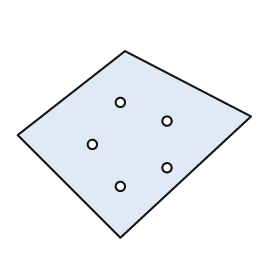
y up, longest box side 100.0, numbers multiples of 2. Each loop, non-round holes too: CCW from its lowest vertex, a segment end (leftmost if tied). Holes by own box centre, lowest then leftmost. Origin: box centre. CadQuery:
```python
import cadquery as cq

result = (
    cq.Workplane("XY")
    .moveTo(-6.0, -40.0)
    .lineTo(50.0, 12.0)
    .lineTo(-4.0, 40.0)
    .lineTo(-50.0, 4.0)
    .close()
    .moveTo(-6.0, -18.0)
    .circle(2.0)
    .moveTo(14.0, -10.0)
    .circle(2.0)
    .moveTo(-18.0, 0.0)
    .circle(2.0)
    .moveTo(14.0, 10.0)
    .circle(2.0)
    .moveTo(-6.0, 18.0)
    .circle(2.0)
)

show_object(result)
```